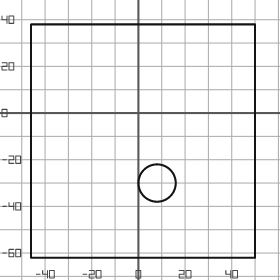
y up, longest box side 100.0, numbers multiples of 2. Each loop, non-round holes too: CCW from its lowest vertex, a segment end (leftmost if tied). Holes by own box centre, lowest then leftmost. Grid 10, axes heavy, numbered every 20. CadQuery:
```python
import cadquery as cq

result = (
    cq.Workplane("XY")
    .moveTo(-46.0, -62.0)
    .lineTo(50.0, -62.0)
    .lineTo(50.0, 38.0)
    .lineTo(-46.0, 38.0)
    .close()
    .moveTo(8.0, -30.0)
    .circle(8.0)
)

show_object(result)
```